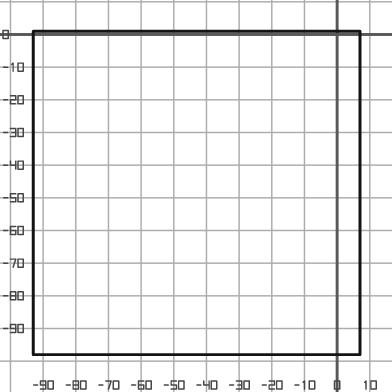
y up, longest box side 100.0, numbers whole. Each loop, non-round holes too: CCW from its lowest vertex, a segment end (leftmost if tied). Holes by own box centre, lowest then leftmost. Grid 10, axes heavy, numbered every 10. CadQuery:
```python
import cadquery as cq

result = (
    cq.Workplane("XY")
    .moveTo(-93.0, -98.0)
    .lineTo(7.0, -98.0)
    .lineTo(7.0, 1.0)
    .lineTo(-93.0, 1.0)
    .close()
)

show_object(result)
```